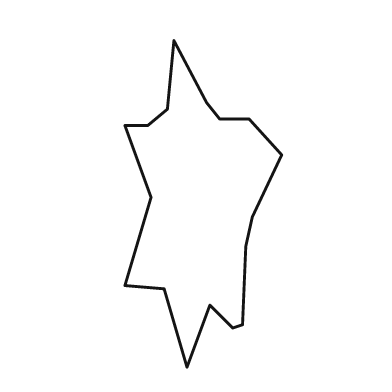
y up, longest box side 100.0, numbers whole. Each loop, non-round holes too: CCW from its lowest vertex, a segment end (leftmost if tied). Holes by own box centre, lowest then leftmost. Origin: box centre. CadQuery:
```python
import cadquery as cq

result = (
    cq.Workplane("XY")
    .moveTo(-5.0, -50.0)
    .lineTo(2.0, -31.0)
    .lineTo(9.0, -38.0)
    .lineTo(12.0, -37.0)
    .lineTo(13.0, -13.0)
    .lineTo(15.0, -4.0)
    .lineTo(24.0, 15.0)
    .lineTo(14.0, 26.0)
    .lineTo(5.0, 26.0)
    .lineTo(1.0, 31.0)
    .lineTo(-9.0, 50.0)
    .lineTo(-11.0, 29.0)
    .lineTo(-17.0, 24.0)
    .lineTo(-24.0, 24.0)
    .lineTo(-16.0, 2.0)
    .lineTo(-24.0, -25.0)
    .lineTo(-12.0, -26.0)
    .close()
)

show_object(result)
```